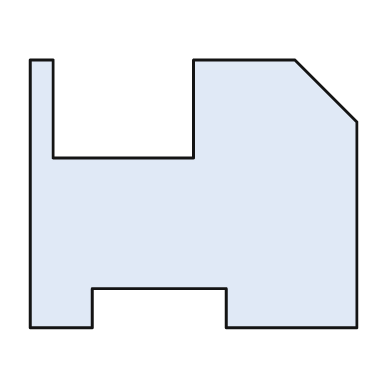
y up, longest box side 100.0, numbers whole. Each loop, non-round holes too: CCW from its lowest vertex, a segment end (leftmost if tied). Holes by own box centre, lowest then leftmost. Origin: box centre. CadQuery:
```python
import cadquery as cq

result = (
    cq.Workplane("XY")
    .moveTo(-50.0, -41.0)
    .lineTo(-31.0, -41.0)
    .lineTo(-31.0, -29.0)
    .lineTo(10.0, -29.0)
    .lineTo(10.0, -41.0)
    .lineTo(50.0, -41.0)
    .lineTo(50.0, 22.0)
    .lineTo(31.0, 41.0)
    .lineTo(0.0, 41.0)
    .lineTo(0.0, 11.0)
    .lineTo(-43.0, 11.0)
    .lineTo(-43.0, 41.0)
    .lineTo(-50.0, 41.0)
    .close()
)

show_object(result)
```